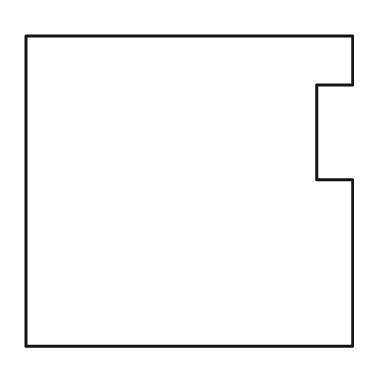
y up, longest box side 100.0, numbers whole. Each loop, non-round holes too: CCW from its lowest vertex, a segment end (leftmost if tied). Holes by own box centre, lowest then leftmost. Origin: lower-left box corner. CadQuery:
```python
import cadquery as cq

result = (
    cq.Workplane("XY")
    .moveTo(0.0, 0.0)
    .lineTo(100.0, 0.0)
    .lineTo(100.0, 51.0)
    .lineTo(89.0, 51.0)
    .lineTo(89.0, 80.0)
    .lineTo(100.0, 80.0)
    .lineTo(100.0, 95.0)
    .lineTo(0.0, 95.0)
    .close()
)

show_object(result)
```